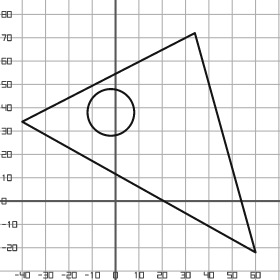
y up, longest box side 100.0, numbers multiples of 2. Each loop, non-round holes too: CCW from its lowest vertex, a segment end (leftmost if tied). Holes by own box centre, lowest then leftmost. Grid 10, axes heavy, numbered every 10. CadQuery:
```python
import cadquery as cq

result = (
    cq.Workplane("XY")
    .moveTo(60.0, -22.0)
    .lineTo(34.0, 72.0)
    .lineTo(-40.0, 34.0)
    .close()
    .moveTo(-2.0, 38.0)
    .circle(10.0)
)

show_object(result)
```